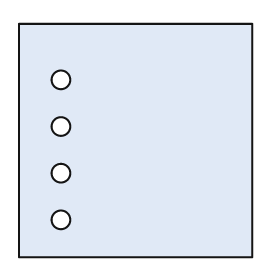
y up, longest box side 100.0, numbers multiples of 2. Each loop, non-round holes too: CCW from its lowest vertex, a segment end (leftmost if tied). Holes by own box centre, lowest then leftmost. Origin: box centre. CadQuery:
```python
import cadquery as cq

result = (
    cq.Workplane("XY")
    .moveTo(-50.0, -50.0)
    .lineTo(50.0, -50.0)
    .lineTo(50.0, 50.0)
    .lineTo(-50.0, 50.0)
    .close()
    .moveTo(-32.0, -34.0)
    .circle(4.0)
    .moveTo(-32.0, -14.0)
    .circle(4.0)
    .moveTo(-32.0, 6.0)
    .circle(4.0)
    .moveTo(-32.0, 26.0)
    .circle(4.0)
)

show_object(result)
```